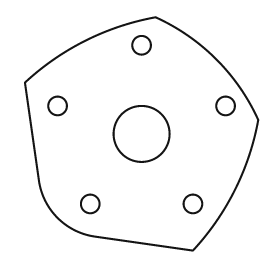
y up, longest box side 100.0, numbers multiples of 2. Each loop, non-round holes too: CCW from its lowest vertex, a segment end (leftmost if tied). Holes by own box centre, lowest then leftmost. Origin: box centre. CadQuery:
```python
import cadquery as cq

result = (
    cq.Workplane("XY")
    .moveTo(22.0, -50.0)
    .threePointArc((40.0, -24.0), (50.0, 6.0))
    .threePointArc((32.0, 32.0), (6.0, 50.0))
    .threePointArc((-24.0, 40.0), (-50.0, 22.0))
    .lineTo(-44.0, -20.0)
    .threePointArc((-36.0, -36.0), (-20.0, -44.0))
    .close()
    .moveTo(-22.0, -30.0)
    .circle(4.0)
    .moveTo(22.0, -30.0)
    .circle(4.0)
    .moveTo(0.0, 0.0)
    .circle(12.0)
    .moveTo(-36.0, 12.0)
    .circle(4.0)
    .moveTo(36.0, 12.0)
    .circle(4.0)
    .moveTo(0.0, 38.0)
    .circle(4.0)
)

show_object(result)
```